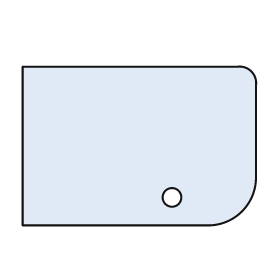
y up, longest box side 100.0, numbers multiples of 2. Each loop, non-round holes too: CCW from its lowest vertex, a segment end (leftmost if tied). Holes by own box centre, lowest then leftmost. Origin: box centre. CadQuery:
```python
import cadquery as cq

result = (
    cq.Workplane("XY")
    .moveTo(-50.0, -34.0)
    .lineTo(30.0, -34.0)
    .threePointArc((44.0, -28.0), (50.0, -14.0))
    .lineTo(50.0, 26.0)
    .threePointArc((48.0, 32.0), (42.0, 34.0))
    .lineTo(-50.0, 34.0)
    .close()
    .moveTo(14.0, -22.0)
    .circle(4.0)
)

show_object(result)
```